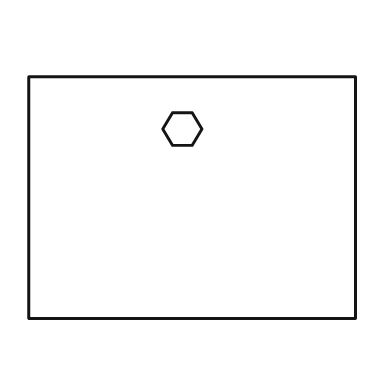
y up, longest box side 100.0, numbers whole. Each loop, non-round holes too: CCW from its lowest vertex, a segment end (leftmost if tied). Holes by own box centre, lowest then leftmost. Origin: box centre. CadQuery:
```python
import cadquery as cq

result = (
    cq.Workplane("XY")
    .moveTo(-50.0, -37.0)
    .lineTo(50.0, -37.0)
    .lineTo(50.0, 37.0)
    .lineTo(-50.0, 37.0)
    .close()
    .moveTo(-6.0, 16.0)
    .lineTo(0.0, 16.0)
    .lineTo(3.0, 21.0)
    .lineTo(0.0, 26.0)
    .lineTo(-6.0, 26.0)
    .lineTo(-9.0, 21.0)
    .close()
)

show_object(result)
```